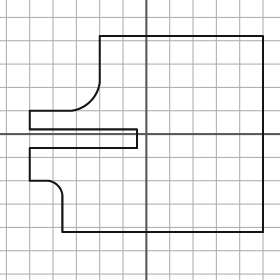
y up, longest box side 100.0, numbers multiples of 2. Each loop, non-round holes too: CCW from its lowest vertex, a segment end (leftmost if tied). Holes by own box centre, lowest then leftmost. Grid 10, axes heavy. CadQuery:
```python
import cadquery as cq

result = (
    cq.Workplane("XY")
    .moveTo(-36.0, -42.0)
    .lineTo(50.0, -42.0)
    .lineTo(50.0, 42.0)
    .lineTo(-20.0, 42.0)
    .lineTo(-20.0, 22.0)
    .threePointArc((-24.0, 14.0), (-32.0, 10.0))
    .lineTo(-50.0, 10.0)
    .lineTo(-50.0, 2.0)
    .lineTo(-4.0, 2.0)
    .lineTo(-4.0, -6.0)
    .lineTo(-50.0, -6.0)
    .lineTo(-50.0, -20.0)
    .lineTo(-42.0, -20.0)
    .threePointArc((-38.0, -22.0), (-36.0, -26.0))
    .close()
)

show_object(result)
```